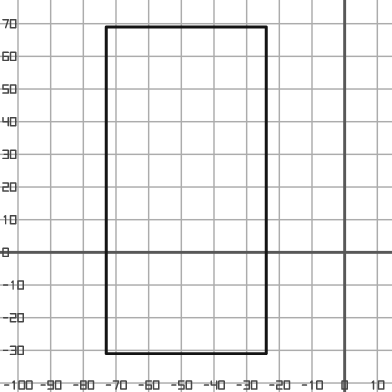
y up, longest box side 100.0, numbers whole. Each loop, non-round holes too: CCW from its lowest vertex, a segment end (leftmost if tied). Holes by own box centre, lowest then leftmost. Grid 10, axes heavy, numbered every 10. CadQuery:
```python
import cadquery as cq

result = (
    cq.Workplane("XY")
    .moveTo(-73.0, -31.0)
    .lineTo(-24.0, -31.0)
    .lineTo(-24.0, 69.0)
    .lineTo(-73.0, 69.0)
    .close()
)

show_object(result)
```